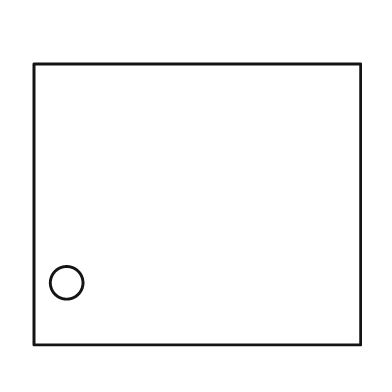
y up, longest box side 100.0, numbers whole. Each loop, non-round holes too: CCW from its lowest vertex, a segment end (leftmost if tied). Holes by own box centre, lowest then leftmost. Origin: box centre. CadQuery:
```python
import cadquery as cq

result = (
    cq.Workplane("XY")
    .moveTo(-50.0, -43.0)
    .lineTo(50.0, -43.0)
    .lineTo(50.0, 43.0)
    .lineTo(-50.0, 43.0)
    .close()
    .moveTo(-40.0, -24.0)
    .circle(5.0)
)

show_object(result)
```